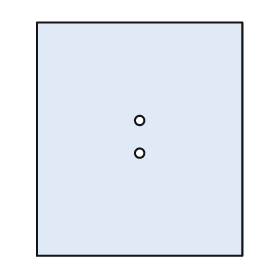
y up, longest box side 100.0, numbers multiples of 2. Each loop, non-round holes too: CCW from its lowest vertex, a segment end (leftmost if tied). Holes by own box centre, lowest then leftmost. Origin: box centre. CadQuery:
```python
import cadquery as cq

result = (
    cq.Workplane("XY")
    .moveTo(-44.0, -50.0)
    .lineTo(44.0, -50.0)
    .lineTo(44.0, 50.0)
    .lineTo(-44.0, 50.0)
    .close()
    .moveTo(0.0, -6.0)
    .circle(2.0)
    .moveTo(0.0, 8.0)
    .circle(2.0)
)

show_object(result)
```